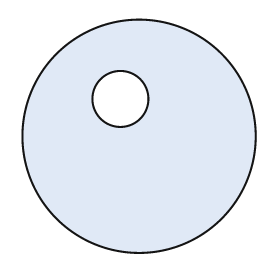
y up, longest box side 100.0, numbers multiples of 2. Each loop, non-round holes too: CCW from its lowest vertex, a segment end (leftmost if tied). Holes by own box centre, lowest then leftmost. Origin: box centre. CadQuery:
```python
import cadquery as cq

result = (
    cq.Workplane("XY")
    .moveTo(0.0, 0.0)
    .circle(50.0)
    .moveTo(-8.0, 16.0)
    .circle(12.0)
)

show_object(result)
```